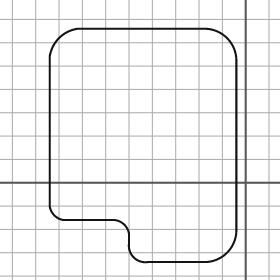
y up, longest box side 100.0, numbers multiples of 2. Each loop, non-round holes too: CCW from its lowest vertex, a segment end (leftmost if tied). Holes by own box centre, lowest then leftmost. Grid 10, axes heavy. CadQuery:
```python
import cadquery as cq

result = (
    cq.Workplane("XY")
    .moveTo(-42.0, -34.0)
    .lineTo(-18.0, -34.0)
    .threePointArc((-8.0, -30.0), (-4.0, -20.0))
    .lineTo(-4.0, 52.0)
    .threePointArc((-8.0, 62.0), (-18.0, 66.0))
    .lineTo(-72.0, 66.0)
    .threePointArc((-80.0, 62.0), (-84.0, 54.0))
    .lineTo(-84.0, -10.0)
    .threePointArc((-82.0, -14.0), (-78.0, -16.0))
    .lineTo(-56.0, -16.0)
    .threePointArc((-52.0, -18.0), (-50.0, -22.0))
    .lineTo(-50.0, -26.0)
    .threePointArc((-48.0, -32.0), (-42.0, -34.0))
    .close()
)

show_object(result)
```